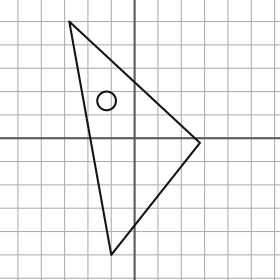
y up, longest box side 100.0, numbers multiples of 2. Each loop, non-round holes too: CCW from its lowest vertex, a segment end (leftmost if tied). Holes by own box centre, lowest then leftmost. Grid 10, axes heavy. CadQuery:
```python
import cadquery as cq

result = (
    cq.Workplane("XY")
    .moveTo(-10.0, -50.0)
    .lineTo(28.0, -2.0)
    .lineTo(-28.0, 50.0)
    .close()
    .moveTo(-12.0, 16.0)
    .circle(4.0)
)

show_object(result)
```